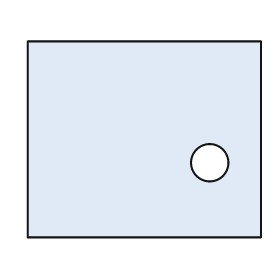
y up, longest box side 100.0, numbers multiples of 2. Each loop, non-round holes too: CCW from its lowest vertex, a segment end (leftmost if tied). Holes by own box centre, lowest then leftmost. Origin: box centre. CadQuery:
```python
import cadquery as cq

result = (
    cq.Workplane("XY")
    .moveTo(-50.0, -42.0)
    .lineTo(50.0, -42.0)
    .lineTo(50.0, 42.0)
    .lineTo(-50.0, 42.0)
    .close()
    .moveTo(28.0, -10.0)
    .circle(8.0)
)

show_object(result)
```